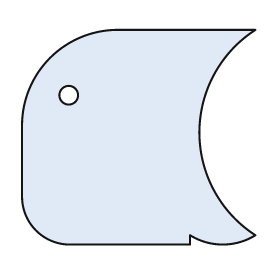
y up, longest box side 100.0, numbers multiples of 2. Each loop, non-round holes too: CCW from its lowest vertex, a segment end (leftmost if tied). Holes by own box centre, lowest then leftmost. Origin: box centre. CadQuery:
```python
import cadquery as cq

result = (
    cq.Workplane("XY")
    .moveTo(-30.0, -46.0)
    .lineTo(22.0, -46.0)
    .lineTo(22.0, -42.0)
    .threePointArc((36.0, -46.0), (50.0, -42.0))
    .threePointArc((26.0, 2.0), (50.0, 46.0))
    .lineTo(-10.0, 46.0)
    .threePointArc((-38.0, 34.0), (-50.0, 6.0))
    .lineTo(-50.0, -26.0)
    .threePointArc((-44.0, -40.0), (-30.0, -46.0))
    .close()
    .moveTo(-30.0, 18.0)
    .circle(4.0)
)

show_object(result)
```